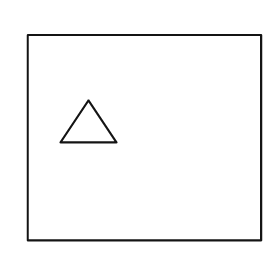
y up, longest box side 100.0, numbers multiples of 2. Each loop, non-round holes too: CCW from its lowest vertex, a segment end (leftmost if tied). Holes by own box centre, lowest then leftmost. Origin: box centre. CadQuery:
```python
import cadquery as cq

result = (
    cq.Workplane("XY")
    .moveTo(-50.0, -44.0)
    .lineTo(50.0, -44.0)
    .lineTo(50.0, 44.0)
    .lineTo(-50.0, 44.0)
    .close()
    .moveTo(-36.0, -2.0)
    .lineTo(-12.0, -2.0)
    .lineTo(-24.0, 16.0)
    .close()
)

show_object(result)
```